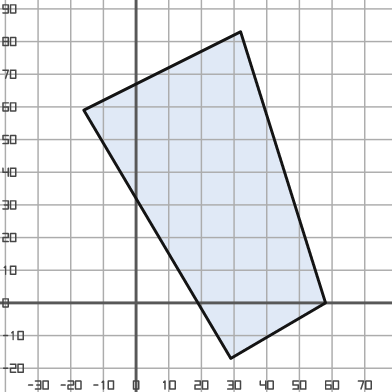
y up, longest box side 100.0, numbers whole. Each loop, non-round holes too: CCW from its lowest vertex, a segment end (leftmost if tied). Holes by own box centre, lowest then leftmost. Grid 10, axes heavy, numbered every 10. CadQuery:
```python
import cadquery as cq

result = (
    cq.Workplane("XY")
    .moveTo(29.0, -17.0)
    .lineTo(58.0, 0.0)
    .lineTo(32.0, 83.0)
    .lineTo(-16.0, 59.0)
    .close()
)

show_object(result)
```